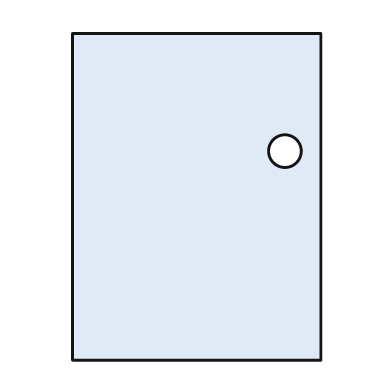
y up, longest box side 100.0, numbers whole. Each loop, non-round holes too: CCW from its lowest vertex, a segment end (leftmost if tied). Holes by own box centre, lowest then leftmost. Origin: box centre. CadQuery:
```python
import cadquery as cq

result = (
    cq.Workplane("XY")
    .moveTo(-38.0, -50.0)
    .lineTo(38.0, -50.0)
    .lineTo(38.0, 50.0)
    .lineTo(-38.0, 50.0)
    .close()
    .moveTo(27.0, 14.0)
    .circle(5.0)
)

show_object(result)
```